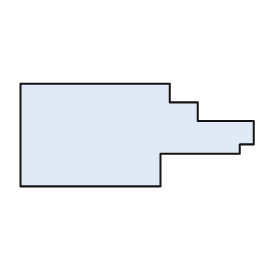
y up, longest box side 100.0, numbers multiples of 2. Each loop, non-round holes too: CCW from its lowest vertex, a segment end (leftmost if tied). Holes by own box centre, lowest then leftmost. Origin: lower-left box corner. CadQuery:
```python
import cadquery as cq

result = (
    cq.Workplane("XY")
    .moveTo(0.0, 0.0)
    .lineTo(60.0, 0.0)
    .lineTo(60.0, 14.0)
    .lineTo(94.0, 14.0)
    .lineTo(94.0, 18.0)
    .lineTo(100.0, 18.0)
    .lineTo(100.0, 28.0)
    .lineTo(76.0, 28.0)
    .lineTo(76.0, 36.0)
    .lineTo(64.0, 36.0)
    .lineTo(64.0, 44.0)
    .lineTo(0.0, 44.0)
    .close()
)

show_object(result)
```